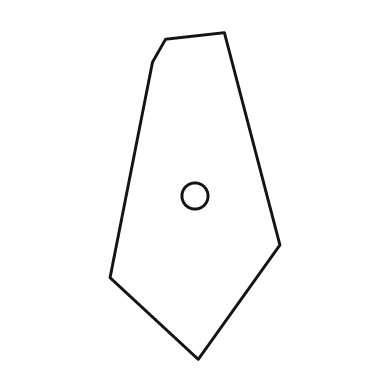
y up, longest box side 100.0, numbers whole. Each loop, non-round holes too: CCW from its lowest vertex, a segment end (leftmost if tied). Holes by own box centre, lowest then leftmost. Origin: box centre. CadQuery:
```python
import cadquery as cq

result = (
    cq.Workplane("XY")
    .moveTo(1.0, -50.0)
    .lineTo(26.0, -15.0)
    .lineTo(9.0, 50.0)
    .lineTo(-9.0, 48.0)
    .lineTo(-13.0, 41.0)
    .lineTo(-26.0, -25.0)
    .close()
    .moveTo(0.0, 0.0)
    .circle(4.0)
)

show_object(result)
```